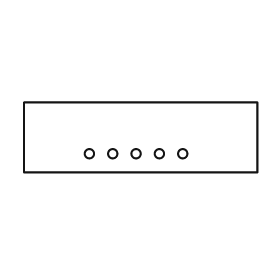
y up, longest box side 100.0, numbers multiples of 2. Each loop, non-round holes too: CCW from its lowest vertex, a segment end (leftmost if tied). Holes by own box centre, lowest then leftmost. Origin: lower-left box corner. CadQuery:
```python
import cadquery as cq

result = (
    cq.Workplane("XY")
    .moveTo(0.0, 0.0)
    .lineTo(100.0, 0.0)
    .lineTo(100.0, 30.0)
    .lineTo(0.0, 30.0)
    .close()
    .moveTo(28.0, 8.0)
    .circle(2.0)
    .moveTo(38.0, 8.0)
    .circle(2.0)
    .moveTo(48.0, 8.0)
    .circle(2.0)
    .moveTo(58.0, 8.0)
    .circle(2.0)
    .moveTo(68.0, 8.0)
    .circle(2.0)
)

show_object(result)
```